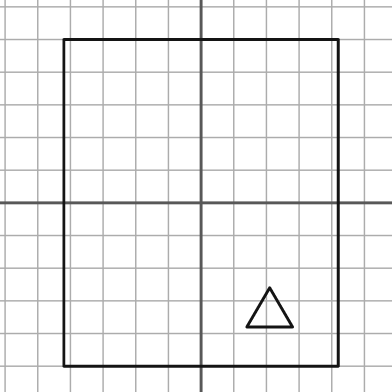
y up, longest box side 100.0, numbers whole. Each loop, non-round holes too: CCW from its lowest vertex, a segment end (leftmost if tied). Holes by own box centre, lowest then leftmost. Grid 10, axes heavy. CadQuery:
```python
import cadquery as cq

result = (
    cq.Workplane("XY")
    .moveTo(-42.0, -50.0)
    .lineTo(42.0, -50.0)
    .lineTo(42.0, 50.0)
    .lineTo(-42.0, 50.0)
    .close()
    .moveTo(14.0, -38.0)
    .lineTo(28.0, -38.0)
    .lineTo(21.0, -26.0)
    .close()
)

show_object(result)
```